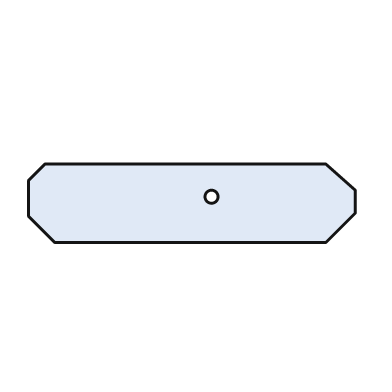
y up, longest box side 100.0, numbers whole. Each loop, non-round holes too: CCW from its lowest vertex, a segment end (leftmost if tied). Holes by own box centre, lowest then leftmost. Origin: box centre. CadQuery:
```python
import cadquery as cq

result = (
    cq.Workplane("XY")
    .moveTo(-42.0, -12.0)
    .lineTo(41.0, -12.0)
    .lineTo(50.0, -3.0)
    .lineTo(50.0, 4.0)
    .lineTo(41.0, 12.0)
    .lineTo(-45.0, 12.0)
    .lineTo(-50.0, 7.0)
    .lineTo(-50.0, -4.0)
    .close()
    .moveTo(6.0, 2.0)
    .circle(2.0)
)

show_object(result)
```